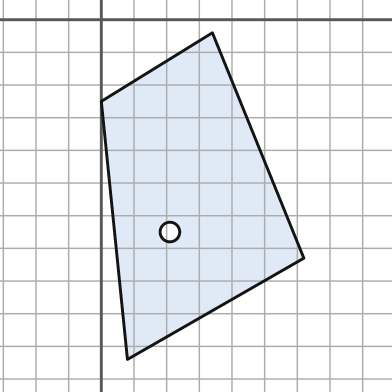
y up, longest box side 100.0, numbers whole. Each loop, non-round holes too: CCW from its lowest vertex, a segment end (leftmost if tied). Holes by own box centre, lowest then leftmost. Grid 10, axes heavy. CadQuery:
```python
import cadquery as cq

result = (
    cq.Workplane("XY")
    .moveTo(8.0, -104.0)
    .lineTo(62.0, -73.0)
    .lineTo(34.0, -4.0)
    .lineTo(0.0, -25.0)
    .close()
    .moveTo(21.0, -65.0)
    .circle(3.0)
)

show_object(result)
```